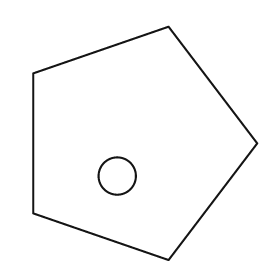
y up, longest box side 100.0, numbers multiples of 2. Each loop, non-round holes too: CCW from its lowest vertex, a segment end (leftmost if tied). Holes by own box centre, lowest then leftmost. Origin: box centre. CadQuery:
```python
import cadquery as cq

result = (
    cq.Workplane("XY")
    .moveTo(10.0, -50.0)
    .lineTo(48.0, 0.0)
    .lineTo(10.0, 50.0)
    .lineTo(-48.0, 30.0)
    .lineTo(-48.0, -30.0)
    .close()
    .moveTo(-12.0, -14.0)
    .circle(8.0)
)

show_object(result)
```